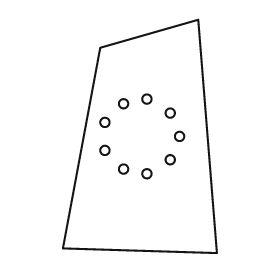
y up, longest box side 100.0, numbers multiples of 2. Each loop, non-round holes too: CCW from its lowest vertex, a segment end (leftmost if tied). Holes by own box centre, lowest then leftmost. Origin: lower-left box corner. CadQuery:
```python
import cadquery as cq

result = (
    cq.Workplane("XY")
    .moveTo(66.0, 0.0)
    .lineTo(58.0, 100.0)
    .lineTo(16.0, 88.0)
    .lineTo(0.0, 2.0)
    .close()
    .moveTo(36.0, 34.0)
    .circle(2.0)
    .moveTo(26.0, 36.0)
    .circle(2.0)
    .moveTo(46.0, 40.0)
    .circle(2.0)
    .moveTo(18.0, 44.0)
    .circle(2.0)
    .moveTo(50.0, 50.0)
    .circle(2.0)
    .moveTo(18.0, 56.0)
    .circle(2.0)
    .moveTo(46.0, 60.0)
    .circle(2.0)
    .moveTo(26.0, 64.0)
    .circle(2.0)
    .moveTo(36.0, 66.0)
    .circle(2.0)
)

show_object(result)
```